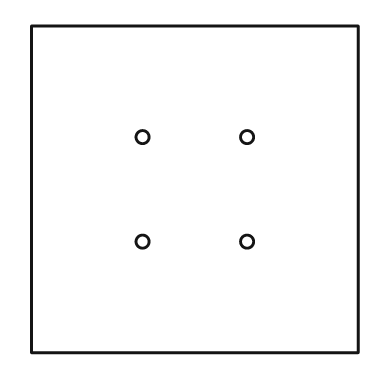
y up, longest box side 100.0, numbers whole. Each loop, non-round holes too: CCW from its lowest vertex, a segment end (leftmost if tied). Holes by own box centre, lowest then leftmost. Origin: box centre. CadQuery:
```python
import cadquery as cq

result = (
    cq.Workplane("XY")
    .moveTo(-50.0, -50.0)
    .lineTo(50.0, -50.0)
    .lineTo(50.0, 50.0)
    .lineTo(-50.0, 50.0)
    .close()
    .moveTo(-16.0, -16.0)
    .circle(2.0)
    .moveTo(16.0, -16.0)
    .circle(2.0)
    .moveTo(-16.0, 16.0)
    .circle(2.0)
    .moveTo(16.0, 16.0)
    .circle(2.0)
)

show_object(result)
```